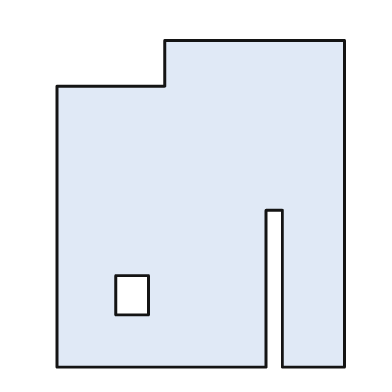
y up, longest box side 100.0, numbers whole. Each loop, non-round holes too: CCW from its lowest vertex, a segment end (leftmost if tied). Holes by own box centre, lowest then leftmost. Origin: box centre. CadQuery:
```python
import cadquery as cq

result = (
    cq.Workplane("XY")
    .moveTo(-44.0, -50.0)
    .lineTo(20.0, -50.0)
    .lineTo(20.0, -2.0)
    .lineTo(25.0, -2.0)
    .lineTo(25.0, -50.0)
    .lineTo(44.0, -50.0)
    .lineTo(44.0, 50.0)
    .lineTo(-11.0, 50.0)
    .lineTo(-11.0, 36.0)
    .lineTo(-44.0, 36.0)
    .close()
    .moveTo(-26.0, -34.0)
    .lineTo(-16.0, -34.0)
    .lineTo(-16.0, -22.0)
    .lineTo(-26.0, -22.0)
    .close()
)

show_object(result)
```